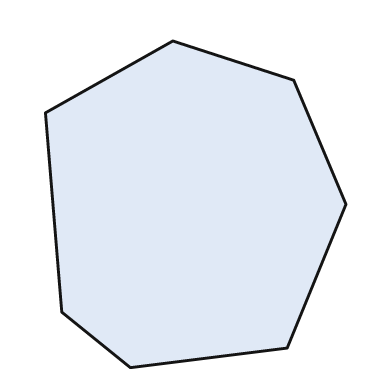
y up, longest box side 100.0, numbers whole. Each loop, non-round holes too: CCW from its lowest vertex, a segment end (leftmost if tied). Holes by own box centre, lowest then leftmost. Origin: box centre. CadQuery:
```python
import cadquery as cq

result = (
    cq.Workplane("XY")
    .moveTo(-20.0, -50.0)
    .lineTo(28.0, -44.0)
    .lineTo(46.0, 0.0)
    .lineTo(30.0, 38.0)
    .lineTo(-7.0, 50.0)
    .lineTo(-46.0, 28.0)
    .lineTo(-41.0, -33.0)
    .close()
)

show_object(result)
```